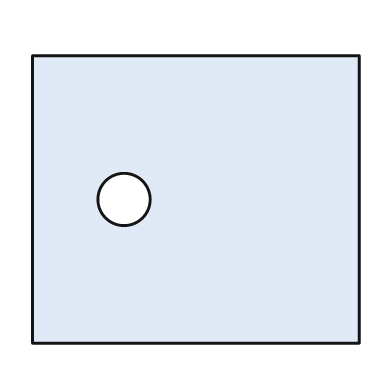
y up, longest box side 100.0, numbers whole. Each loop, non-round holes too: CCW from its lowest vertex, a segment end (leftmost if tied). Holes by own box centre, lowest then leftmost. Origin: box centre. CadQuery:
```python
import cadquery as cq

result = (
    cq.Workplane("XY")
    .moveTo(-50.0, -44.0)
    .lineTo(50.0, -44.0)
    .lineTo(50.0, 44.0)
    .lineTo(-50.0, 44.0)
    .close()
    .moveTo(-22.0, 0.0)
    .circle(8.0)
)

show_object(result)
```